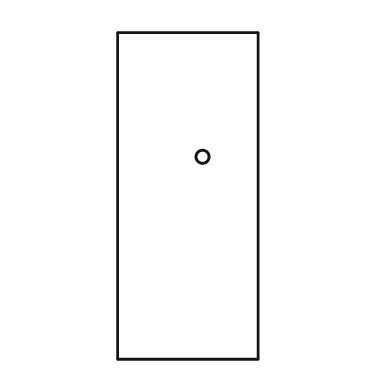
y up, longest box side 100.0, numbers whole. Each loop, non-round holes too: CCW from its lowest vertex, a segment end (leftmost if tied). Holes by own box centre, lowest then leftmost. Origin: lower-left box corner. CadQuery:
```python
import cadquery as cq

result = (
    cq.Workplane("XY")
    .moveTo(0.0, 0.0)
    .lineTo(43.0, 0.0)
    .lineTo(43.0, 100.0)
    .lineTo(0.0, 100.0)
    .close()
    .moveTo(26.0, 62.0)
    .circle(2.0)
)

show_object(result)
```